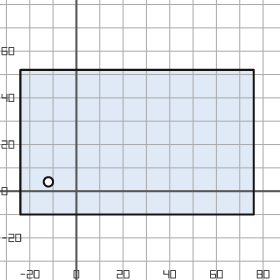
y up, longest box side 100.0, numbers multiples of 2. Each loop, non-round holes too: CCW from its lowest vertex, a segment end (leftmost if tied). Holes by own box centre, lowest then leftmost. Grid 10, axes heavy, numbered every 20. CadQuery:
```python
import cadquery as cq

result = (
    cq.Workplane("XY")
    .moveTo(-24.0, -10.0)
    .lineTo(76.0, -10.0)
    .lineTo(76.0, 52.0)
    .lineTo(-24.0, 52.0)
    .close()
    .moveTo(-12.0, 4.0)
    .circle(2.0)
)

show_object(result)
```